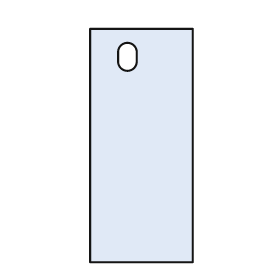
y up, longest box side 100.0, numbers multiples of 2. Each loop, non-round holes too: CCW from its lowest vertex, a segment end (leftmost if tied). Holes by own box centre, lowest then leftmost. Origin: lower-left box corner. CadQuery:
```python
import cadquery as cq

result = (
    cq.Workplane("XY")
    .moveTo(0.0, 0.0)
    .lineTo(44.0, 0.0)
    .lineTo(44.0, 100.0)
    .lineTo(0.0, 100.0)
    .close()
    .moveTo(12.0, 86.0)
    .threePointArc((16.0, 82.0), (20.0, 86.0))
    .lineTo(20.0, 90.0)
    .threePointArc((16.0, 94.0), (12.0, 90.0))
    .close()
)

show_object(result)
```